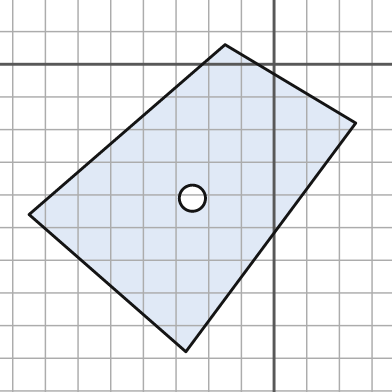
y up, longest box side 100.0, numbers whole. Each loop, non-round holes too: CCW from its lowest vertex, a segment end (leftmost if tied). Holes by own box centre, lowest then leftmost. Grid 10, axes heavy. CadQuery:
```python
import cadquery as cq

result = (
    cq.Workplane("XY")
    .moveTo(-27.0, -88.0)
    .lineTo(25.0, -18.0)
    .lineTo(-15.0, 6.0)
    .lineTo(-75.0, -46.0)
    .close()
    .moveTo(-25.0, -41.0)
    .circle(4.0)
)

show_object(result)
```